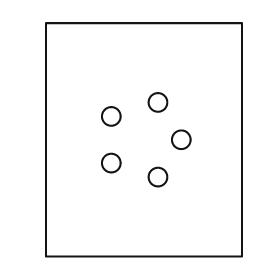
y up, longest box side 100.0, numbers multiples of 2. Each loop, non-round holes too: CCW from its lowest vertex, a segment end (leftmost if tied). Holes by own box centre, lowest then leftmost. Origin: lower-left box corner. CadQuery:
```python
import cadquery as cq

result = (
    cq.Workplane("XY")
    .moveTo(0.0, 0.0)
    .lineTo(84.0, 0.0)
    .lineTo(84.0, 100.0)
    .lineTo(0.0, 100.0)
    .close()
    .moveTo(48.0, 34.0)
    .circle(4.0)
    .moveTo(28.0, 40.0)
    .circle(4.0)
    .moveTo(58.0, 50.0)
    .circle(4.0)
    .moveTo(28.0, 60.0)
    .circle(4.0)
    .moveTo(48.0, 66.0)
    .circle(4.0)
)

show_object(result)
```